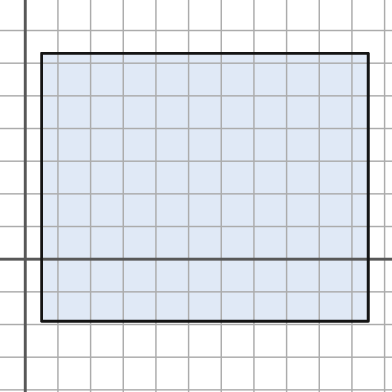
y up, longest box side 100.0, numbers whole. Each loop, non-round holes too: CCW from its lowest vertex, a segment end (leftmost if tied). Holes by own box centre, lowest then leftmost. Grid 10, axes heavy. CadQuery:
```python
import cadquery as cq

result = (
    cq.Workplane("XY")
    .moveTo(5.0, -19.0)
    .lineTo(105.0, -19.0)
    .lineTo(105.0, 63.0)
    .lineTo(5.0, 63.0)
    .close()
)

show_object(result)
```